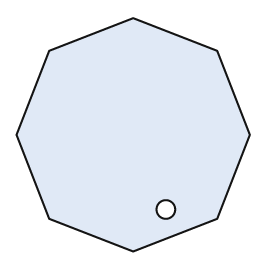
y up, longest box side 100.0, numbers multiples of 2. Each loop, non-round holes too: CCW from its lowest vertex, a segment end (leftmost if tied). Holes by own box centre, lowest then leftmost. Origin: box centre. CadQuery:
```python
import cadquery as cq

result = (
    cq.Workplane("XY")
    .moveTo(0.0, -50.0)
    .lineTo(36.0, -36.0)
    .lineTo(50.0, 0.0)
    .lineTo(36.0, 36.0)
    .lineTo(0.0, 50.0)
    .lineTo(-36.0, 36.0)
    .lineTo(-50.0, 0.0)
    .lineTo(-36.0, -36.0)
    .close()
    .moveTo(14.0, -32.0)
    .circle(4.0)
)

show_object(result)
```